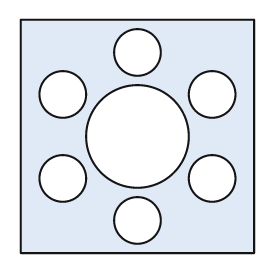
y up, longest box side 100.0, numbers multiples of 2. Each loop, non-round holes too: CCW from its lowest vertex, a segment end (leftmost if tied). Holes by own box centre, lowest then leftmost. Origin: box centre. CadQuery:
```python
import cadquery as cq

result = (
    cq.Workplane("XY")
    .moveTo(-50.0, -50.0)
    .lineTo(50.0, -50.0)
    .lineTo(50.0, 50.0)
    .lineTo(-50.0, 50.0)
    .close()
    .moveTo(0.0, -36.0)
    .circle(10.0)
    .moveTo(-32.0, -18.0)
    .circle(10.0)
    .moveTo(32.0, -18.0)
    .circle(10.0)
    .moveTo(0.0, 0.0)
    .circle(22.0)
    .moveTo(-32.0, 18.0)
    .circle(10.0)
    .moveTo(32.0, 18.0)
    .circle(10.0)
    .moveTo(0.0, 36.0)
    .circle(10.0)
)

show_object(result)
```